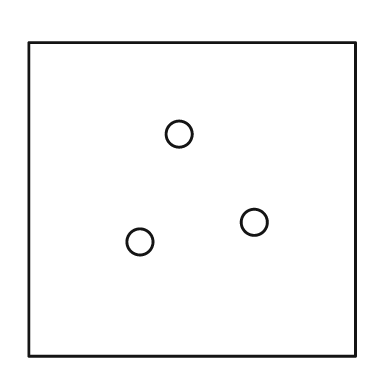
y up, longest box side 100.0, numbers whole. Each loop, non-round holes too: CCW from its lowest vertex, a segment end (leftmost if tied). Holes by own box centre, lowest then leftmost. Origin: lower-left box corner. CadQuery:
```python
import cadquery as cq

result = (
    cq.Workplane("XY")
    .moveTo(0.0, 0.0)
    .lineTo(100.0, 0.0)
    .lineTo(100.0, 96.0)
    .lineTo(0.0, 96.0)
    .close()
    .moveTo(34.0, 35.0)
    .circle(4.0)
    .moveTo(69.0, 41.0)
    .circle(4.0)
    .moveTo(46.0, 68.0)
    .circle(4.0)
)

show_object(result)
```